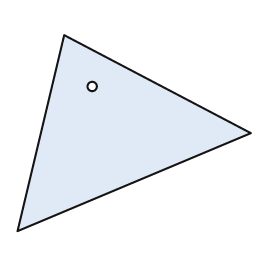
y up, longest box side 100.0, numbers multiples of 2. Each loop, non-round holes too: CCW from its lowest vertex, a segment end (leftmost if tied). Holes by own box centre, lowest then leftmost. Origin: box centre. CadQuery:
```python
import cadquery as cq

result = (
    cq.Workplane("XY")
    .moveTo(-50.0, -42.0)
    .lineTo(50.0, 0.0)
    .lineTo(-30.0, 42.0)
    .close()
    .moveTo(-18.0, 20.0)
    .circle(2.0)
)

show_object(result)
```